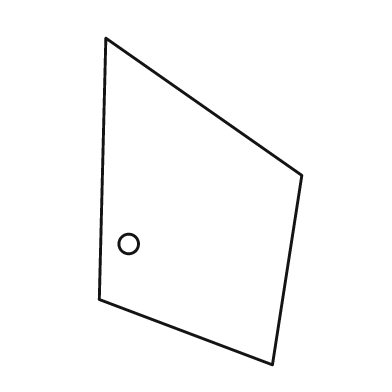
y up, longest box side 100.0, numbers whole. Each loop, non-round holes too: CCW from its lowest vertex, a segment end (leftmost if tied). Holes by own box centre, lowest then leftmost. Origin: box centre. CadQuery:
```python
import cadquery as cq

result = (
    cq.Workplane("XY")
    .moveTo(22.0, -50.0)
    .lineTo(31.0, 8.0)
    .lineTo(-29.0, 50.0)
    .lineTo(-31.0, -30.0)
    .close()
    .moveTo(-22.0, -13.0)
    .circle(3.0)
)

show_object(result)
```